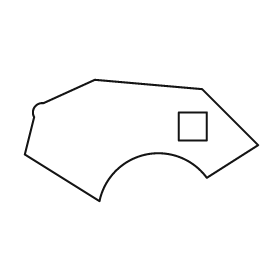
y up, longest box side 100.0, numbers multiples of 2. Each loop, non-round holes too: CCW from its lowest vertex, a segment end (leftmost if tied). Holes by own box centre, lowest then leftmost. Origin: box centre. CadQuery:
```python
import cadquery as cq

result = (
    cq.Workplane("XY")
    .moveTo(-18.0, -26.0)
    .threePointArc((2.0, -6.0), (28.0, -16.0))
    .lineTo(50.0, -2.0)
    .lineTo(26.0, 22.0)
    .lineTo(-20.0, 26.0)
    .lineTo(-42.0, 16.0)
    .threePointArc((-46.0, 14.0), (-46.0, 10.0))
    .lineTo(-50.0, -6.0)
    .close()
    .moveTo(16.0, 0.0)
    .lineTo(28.0, 0.0)
    .lineTo(28.0, 12.0)
    .lineTo(16.0, 12.0)
    .close()
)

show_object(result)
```